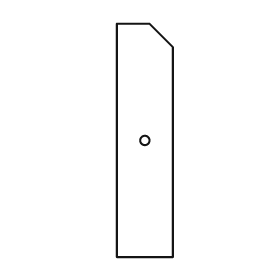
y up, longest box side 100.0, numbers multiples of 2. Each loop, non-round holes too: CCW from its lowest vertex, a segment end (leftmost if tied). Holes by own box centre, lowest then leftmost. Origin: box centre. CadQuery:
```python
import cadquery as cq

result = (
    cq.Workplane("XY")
    .moveTo(-12.0, -50.0)
    .lineTo(12.0, -50.0)
    .lineTo(12.0, 40.0)
    .lineTo(2.0, 50.0)
    .lineTo(-12.0, 50.0)
    .close()
    .moveTo(0.0, 0.0)
    .circle(2.0)
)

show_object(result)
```